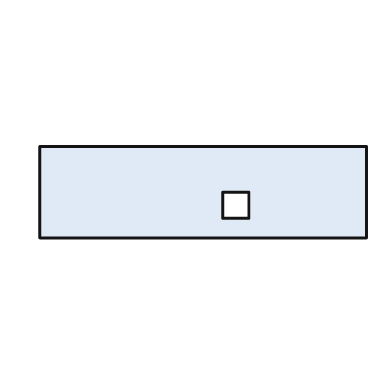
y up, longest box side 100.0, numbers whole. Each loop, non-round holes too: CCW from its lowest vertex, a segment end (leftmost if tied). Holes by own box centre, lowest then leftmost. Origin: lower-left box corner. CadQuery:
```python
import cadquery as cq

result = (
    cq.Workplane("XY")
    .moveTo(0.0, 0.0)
    .lineTo(100.0, 0.0)
    .lineTo(100.0, 28.0)
    .lineTo(0.0, 28.0)
    .close()
    .moveTo(56.0, 6.0)
    .lineTo(64.0, 6.0)
    .lineTo(64.0, 14.0)
    .lineTo(56.0, 14.0)
    .close()
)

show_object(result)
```